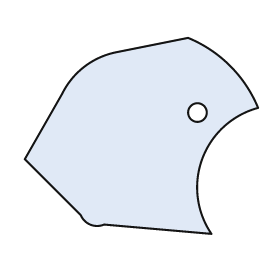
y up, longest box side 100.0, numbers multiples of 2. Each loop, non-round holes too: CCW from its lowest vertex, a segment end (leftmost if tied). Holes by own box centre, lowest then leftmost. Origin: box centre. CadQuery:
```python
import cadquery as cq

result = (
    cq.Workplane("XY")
    .moveTo(30.0, -42.0)
    .threePointArc((26.0, -10.0), (50.0, 12.0))
    .threePointArc((38.0, 30.0), (20.0, 42.0))
    .lineTo(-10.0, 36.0)
    .threePointArc((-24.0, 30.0), (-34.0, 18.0))
    .lineTo(-50.0, -10.0)
    .lineTo(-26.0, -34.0)
    .threePointArc((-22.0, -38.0), (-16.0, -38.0))
    .close()
    .moveTo(24.0, 10.0)
    .circle(4.0)
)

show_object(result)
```